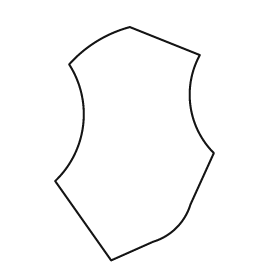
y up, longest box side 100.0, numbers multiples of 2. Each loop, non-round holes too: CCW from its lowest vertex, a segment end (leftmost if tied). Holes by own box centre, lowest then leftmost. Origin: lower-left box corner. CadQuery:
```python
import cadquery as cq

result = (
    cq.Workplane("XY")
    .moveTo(24.0, 0.0)
    .lineTo(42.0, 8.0)
    .threePointArc((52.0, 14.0), (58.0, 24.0))
    .lineTo(68.0, 46.0)
    .threePointArc((58.0, 66.0), (62.0, 88.0))
    .lineTo(32.0, 100.0)
    .threePointArc((18.0, 94.0), (6.0, 84.0))
    .threePointArc((12.0, 58.0), (0.0, 34.0))
    .close()
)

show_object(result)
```